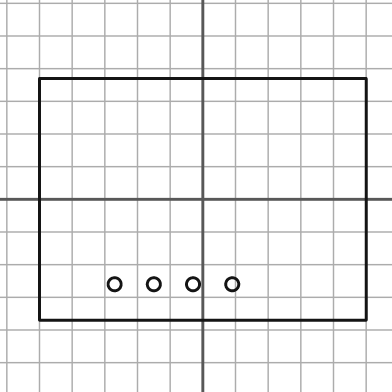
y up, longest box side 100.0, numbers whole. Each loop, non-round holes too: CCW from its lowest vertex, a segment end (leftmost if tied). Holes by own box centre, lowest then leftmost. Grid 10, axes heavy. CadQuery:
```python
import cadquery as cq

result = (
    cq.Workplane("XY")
    .moveTo(-50.0, -37.0)
    .lineTo(50.0, -37.0)
    .lineTo(50.0, 37.0)
    .lineTo(-50.0, 37.0)
    .close()
    .moveTo(-27.0, -26.0)
    .circle(2.0)
    .moveTo(-15.0, -26.0)
    .circle(2.0)
    .moveTo(-3.0, -26.0)
    .circle(2.0)
    .moveTo(9.0, -26.0)
    .circle(2.0)
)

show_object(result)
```